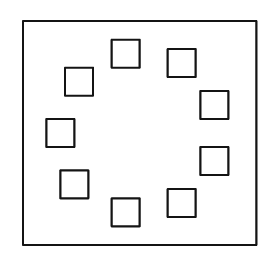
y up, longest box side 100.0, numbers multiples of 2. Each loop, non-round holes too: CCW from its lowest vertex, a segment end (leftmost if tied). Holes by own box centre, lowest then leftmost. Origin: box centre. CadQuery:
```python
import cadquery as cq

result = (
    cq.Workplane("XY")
    .moveTo(-50.0, -48.0)
    .lineTo(50.0, -48.0)
    .lineTo(50.0, 48.0)
    .lineTo(-50.0, 48.0)
    .close()
    .moveTo(-12.0, -40.0)
    .lineTo(0.0, -40.0)
    .lineTo(0.0, -28.0)
    .lineTo(-12.0, -28.0)
    .close()
    .moveTo(12.0, -36.0)
    .lineTo(24.0, -36.0)
    .lineTo(24.0, -24.0)
    .lineTo(12.0, -24.0)
    .close()
    .moveTo(-34.0, -28.0)
    .lineTo(-22.0, -28.0)
    .lineTo(-22.0, -16.0)
    .lineTo(-34.0, -16.0)
    .close()
    .moveTo(26.0, -18.0)
    .lineTo(38.0, -18.0)
    .lineTo(38.0, -6.0)
    .lineTo(26.0, -6.0)
    .close()
    .moveTo(-40.0, -6.0)
    .lineTo(-28.0, -6.0)
    .lineTo(-28.0, 6.0)
    .lineTo(-40.0, 6.0)
    .close()
    .moveTo(26.0, 6.0)
    .lineTo(38.0, 6.0)
    .lineTo(38.0, 18.0)
    .lineTo(26.0, 18.0)
    .close()
    .moveTo(-32.0, 16.0)
    .lineTo(-20.0, 16.0)
    .lineTo(-20.0, 28.0)
    .lineTo(-32.0, 28.0)
    .close()
    .moveTo(12.0, 24.0)
    .lineTo(24.0, 24.0)
    .lineTo(24.0, 36.0)
    .lineTo(12.0, 36.0)
    .close()
    .moveTo(-12.0, 28.0)
    .lineTo(0.0, 28.0)
    .lineTo(0.0, 40.0)
    .lineTo(-12.0, 40.0)
    .close()
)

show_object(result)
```